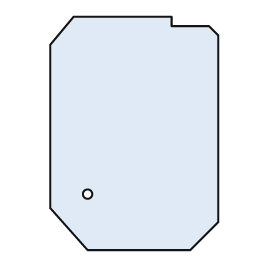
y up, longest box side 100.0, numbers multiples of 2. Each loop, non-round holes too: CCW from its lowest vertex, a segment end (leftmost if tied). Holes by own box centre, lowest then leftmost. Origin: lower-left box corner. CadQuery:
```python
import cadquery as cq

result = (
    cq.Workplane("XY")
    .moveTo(16.0, 0.0)
    .lineTo(60.0, 0.0)
    .lineTo(72.0, 12.0)
    .lineTo(72.0, 92.0)
    .lineTo(68.0, 96.0)
    .lineTo(52.0, 96.0)
    .lineTo(52.0, 100.0)
    .lineTo(10.0, 100.0)
    .lineTo(0.0, 88.0)
    .lineTo(0.0, 18.0)
    .close()
    .moveTo(16.0, 24.0)
    .circle(2.0)
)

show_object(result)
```